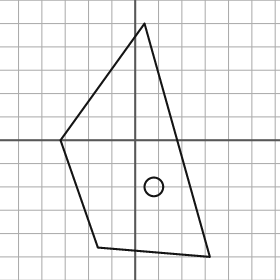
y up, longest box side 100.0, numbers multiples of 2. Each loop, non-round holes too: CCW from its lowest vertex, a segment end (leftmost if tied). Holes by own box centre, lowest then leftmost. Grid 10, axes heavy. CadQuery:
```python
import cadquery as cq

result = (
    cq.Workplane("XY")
    .moveTo(32.0, -50.0)
    .lineTo(4.0, 50.0)
    .lineTo(-32.0, 0.0)
    .lineTo(-16.0, -46.0)
    .close()
    .moveTo(8.0, -20.0)
    .circle(4.0)
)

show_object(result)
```